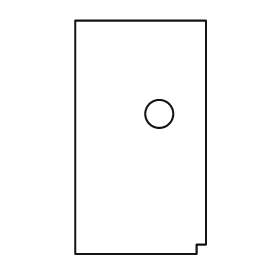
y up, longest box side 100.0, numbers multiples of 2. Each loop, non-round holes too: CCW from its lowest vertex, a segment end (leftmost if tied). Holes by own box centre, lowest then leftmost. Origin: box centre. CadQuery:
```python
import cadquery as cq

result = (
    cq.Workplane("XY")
    .moveTo(-28.0, -50.0)
    .lineTo(24.0, -50.0)
    .lineTo(24.0, -46.0)
    .lineTo(28.0, -46.0)
    .lineTo(28.0, 50.0)
    .lineTo(-28.0, 50.0)
    .close()
    .moveTo(8.0, 10.0)
    .circle(6.0)
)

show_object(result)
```